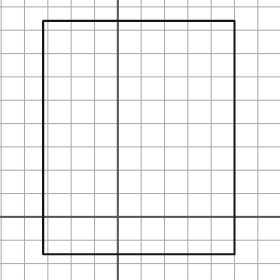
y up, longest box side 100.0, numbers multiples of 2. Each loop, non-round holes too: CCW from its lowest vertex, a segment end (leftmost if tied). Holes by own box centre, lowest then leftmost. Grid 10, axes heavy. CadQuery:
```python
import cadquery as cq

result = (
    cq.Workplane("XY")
    .moveTo(-32.0, -16.0)
    .lineTo(50.0, -16.0)
    .lineTo(50.0, 84.0)
    .lineTo(-32.0, 84.0)
    .close()
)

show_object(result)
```